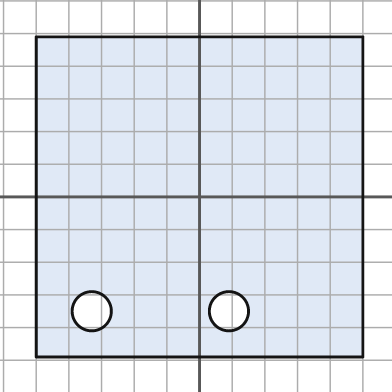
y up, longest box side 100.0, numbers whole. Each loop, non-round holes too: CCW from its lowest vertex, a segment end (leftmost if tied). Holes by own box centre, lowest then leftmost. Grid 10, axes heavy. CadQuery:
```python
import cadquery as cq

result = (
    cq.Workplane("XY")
    .moveTo(-50.0, -49.0)
    .lineTo(50.0, -49.0)
    .lineTo(50.0, 49.0)
    .lineTo(-50.0, 49.0)
    .close()
    .moveTo(-33.0, -35.0)
    .circle(6.0)
    .moveTo(9.0, -35.0)
    .circle(6.0)
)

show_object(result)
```